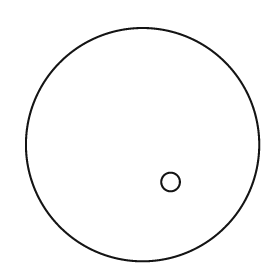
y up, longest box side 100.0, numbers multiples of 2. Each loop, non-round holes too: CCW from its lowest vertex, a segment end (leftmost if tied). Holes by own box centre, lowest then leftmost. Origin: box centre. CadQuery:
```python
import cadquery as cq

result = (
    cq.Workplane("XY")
    .moveTo(0.0, 0.0)
    .circle(50.0)
    .moveTo(12.0, -16.0)
    .circle(4.0)
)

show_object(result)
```